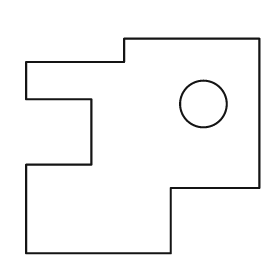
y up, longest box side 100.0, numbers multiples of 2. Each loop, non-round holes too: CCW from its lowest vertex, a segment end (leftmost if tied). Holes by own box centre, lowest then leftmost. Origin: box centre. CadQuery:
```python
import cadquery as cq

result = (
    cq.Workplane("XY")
    .moveTo(-50.0, -46.0)
    .lineTo(12.0, -46.0)
    .lineTo(12.0, -18.0)
    .lineTo(50.0, -18.0)
    .lineTo(50.0, 46.0)
    .lineTo(-8.0, 46.0)
    .lineTo(-8.0, 36.0)
    .lineTo(-50.0, 36.0)
    .lineTo(-50.0, 20.0)
    .lineTo(-22.0, 20.0)
    .lineTo(-22.0, -8.0)
    .lineTo(-50.0, -8.0)
    .close()
    .moveTo(26.0, 18.0)
    .circle(10.0)
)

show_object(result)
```